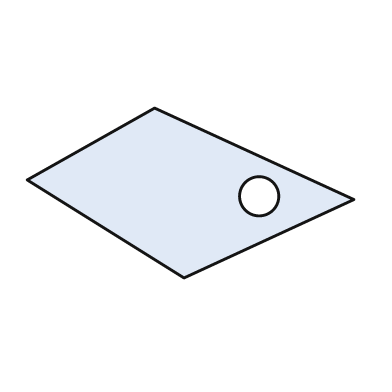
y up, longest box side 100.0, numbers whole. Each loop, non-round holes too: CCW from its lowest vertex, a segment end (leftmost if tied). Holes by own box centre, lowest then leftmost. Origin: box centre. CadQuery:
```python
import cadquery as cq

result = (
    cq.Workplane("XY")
    .moveTo(-2.0, -26.0)
    .lineTo(50.0, -2.0)
    .lineTo(-11.0, 26.0)
    .lineTo(-50.0, 4.0)
    .close()
    .moveTo(21.0, -1.0)
    .circle(6.0)
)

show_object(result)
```